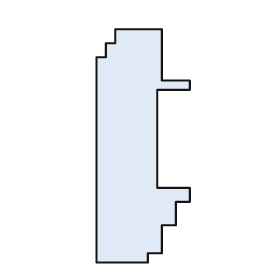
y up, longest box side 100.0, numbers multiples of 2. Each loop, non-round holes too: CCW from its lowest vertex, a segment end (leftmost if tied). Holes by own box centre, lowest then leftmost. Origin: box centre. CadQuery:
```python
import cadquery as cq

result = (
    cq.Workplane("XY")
    .moveTo(-20.0, -50.0)
    .lineTo(2.0, -50.0)
    .lineTo(2.0, -46.0)
    .lineTo(8.0, -46.0)
    .lineTo(8.0, -34.0)
    .lineTo(14.0, -34.0)
    .lineTo(14.0, -24.0)
    .lineTo(20.0, -24.0)
    .lineTo(20.0, -18.0)
    .lineTo(6.0, -18.0)
    .lineTo(6.0, 24.0)
    .lineTo(20.0, 24.0)
    .lineTo(20.0, 28.0)
    .lineTo(8.0, 28.0)
    .lineTo(8.0, 50.0)
    .lineTo(-12.0, 50.0)
    .lineTo(-12.0, 44.0)
    .lineTo(-16.0, 44.0)
    .lineTo(-16.0, 38.0)
    .lineTo(-20.0, 38.0)
    .close()
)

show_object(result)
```